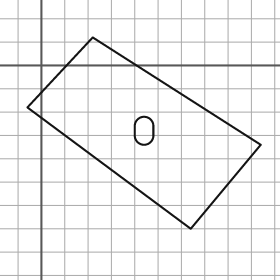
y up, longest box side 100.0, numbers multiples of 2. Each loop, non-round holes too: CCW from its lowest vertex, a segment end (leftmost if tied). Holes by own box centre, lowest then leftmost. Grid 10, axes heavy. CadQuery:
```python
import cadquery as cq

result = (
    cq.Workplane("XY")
    .moveTo(64.0, -70.0)
    .lineTo(94.0, -34.0)
    .lineTo(22.0, 12.0)
    .lineTo(-6.0, -18.0)
    .close()
    .moveTo(40.0, -30.0)
    .threePointArc((44.0, -34.0), (48.0, -30.0))
    .lineTo(48.0, -26.0)
    .threePointArc((44.0, -22.0), (40.0, -26.0))
    .close()
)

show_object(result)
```